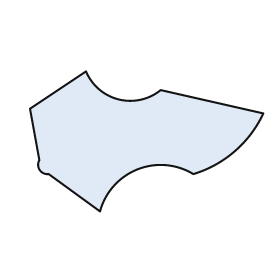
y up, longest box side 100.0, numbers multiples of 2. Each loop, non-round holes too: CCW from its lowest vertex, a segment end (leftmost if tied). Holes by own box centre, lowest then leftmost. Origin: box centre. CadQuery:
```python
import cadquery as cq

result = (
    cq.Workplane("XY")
    .moveTo(-20.0, -30.0)
    .threePointArc((-4.0, -12.0), (20.0, -14.0))
    .threePointArc((38.0, -4.0), (50.0, 12.0))
    .lineTo(6.0, 22.0)
    .threePointArc((-12.0, 18.0), (-26.0, 30.0))
    .lineTo(-50.0, 14.0)
    .lineTo(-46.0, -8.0)
    .threePointArc((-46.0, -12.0), (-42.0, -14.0))
    .close()
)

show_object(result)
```